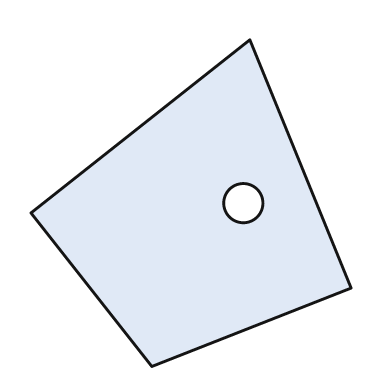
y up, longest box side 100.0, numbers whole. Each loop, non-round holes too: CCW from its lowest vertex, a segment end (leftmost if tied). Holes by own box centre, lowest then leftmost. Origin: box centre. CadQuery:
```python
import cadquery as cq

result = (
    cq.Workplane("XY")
    .moveTo(-12.0, -50.0)
    .lineTo(49.0, -26.0)
    .lineTo(18.0, 50.0)
    .lineTo(-49.0, -3.0)
    .close()
    .moveTo(16.0, 0.0)
    .circle(6.0)
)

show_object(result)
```